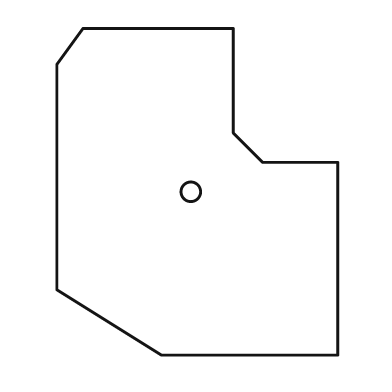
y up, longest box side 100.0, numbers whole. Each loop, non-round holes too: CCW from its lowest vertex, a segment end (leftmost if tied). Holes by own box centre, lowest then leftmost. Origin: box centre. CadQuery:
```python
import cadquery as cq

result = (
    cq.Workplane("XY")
    .moveTo(-11.0, -50.0)
    .lineTo(43.0, -50.0)
    .lineTo(43.0, 9.0)
    .lineTo(20.0, 9.0)
    .lineTo(11.0, 18.0)
    .lineTo(11.0, 50.0)
    .lineTo(-35.0, 50.0)
    .lineTo(-43.0, 39.0)
    .lineTo(-43.0, -30.0)
    .close()
    .moveTo(-2.0, 0.0)
    .circle(3.0)
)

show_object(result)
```